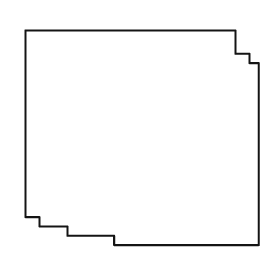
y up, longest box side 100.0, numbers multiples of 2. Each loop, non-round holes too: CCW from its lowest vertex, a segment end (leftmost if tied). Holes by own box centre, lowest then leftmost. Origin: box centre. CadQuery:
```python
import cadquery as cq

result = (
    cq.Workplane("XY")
    .moveTo(-12.0, -46.0)
    .lineTo(50.0, -46.0)
    .lineTo(50.0, 32.0)
    .lineTo(46.0, 32.0)
    .lineTo(46.0, 36.0)
    .lineTo(40.0, 36.0)
    .lineTo(40.0, 46.0)
    .lineTo(-50.0, 46.0)
    .lineTo(-50.0, -34.0)
    .lineTo(-44.0, -34.0)
    .lineTo(-44.0, -38.0)
    .lineTo(-32.0, -38.0)
    .lineTo(-32.0, -42.0)
    .lineTo(-12.0, -42.0)
    .close()
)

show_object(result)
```